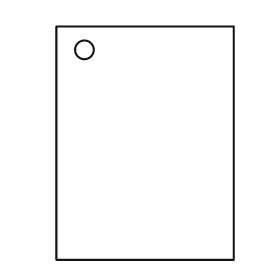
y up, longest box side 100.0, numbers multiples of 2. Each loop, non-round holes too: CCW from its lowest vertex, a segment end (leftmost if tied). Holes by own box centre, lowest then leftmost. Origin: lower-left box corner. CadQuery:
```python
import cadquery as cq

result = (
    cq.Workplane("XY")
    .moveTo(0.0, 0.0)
    .lineTo(76.0, 0.0)
    .lineTo(76.0, 100.0)
    .lineTo(0.0, 100.0)
    .close()
    .moveTo(12.0, 90.0)
    .circle(4.0)
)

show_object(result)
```